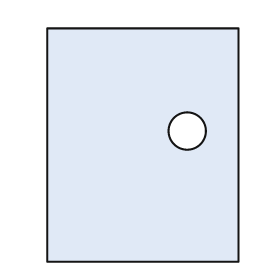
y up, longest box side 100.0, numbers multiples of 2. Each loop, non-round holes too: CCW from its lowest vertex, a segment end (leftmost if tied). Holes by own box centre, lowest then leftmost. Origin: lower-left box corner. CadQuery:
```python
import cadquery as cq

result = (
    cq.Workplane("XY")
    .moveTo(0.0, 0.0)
    .lineTo(82.0, 0.0)
    .lineTo(82.0, 100.0)
    .lineTo(0.0, 100.0)
    .close()
    .moveTo(60.0, 56.0)
    .circle(8.0)
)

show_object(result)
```